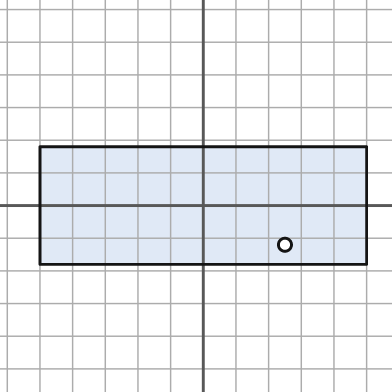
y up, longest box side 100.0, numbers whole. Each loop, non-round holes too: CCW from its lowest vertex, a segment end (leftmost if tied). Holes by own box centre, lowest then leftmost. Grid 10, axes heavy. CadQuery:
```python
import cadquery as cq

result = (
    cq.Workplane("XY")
    .moveTo(-50.0, -18.0)
    .lineTo(50.0, -18.0)
    .lineTo(50.0, 18.0)
    .lineTo(-50.0, 18.0)
    .close()
    .moveTo(25.0, -12.0)
    .circle(2.0)
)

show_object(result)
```